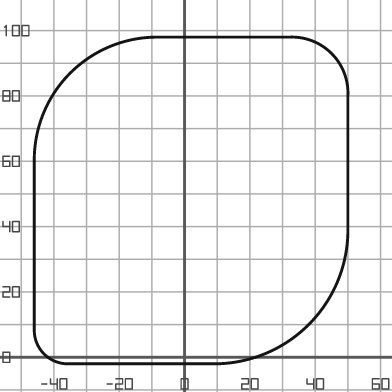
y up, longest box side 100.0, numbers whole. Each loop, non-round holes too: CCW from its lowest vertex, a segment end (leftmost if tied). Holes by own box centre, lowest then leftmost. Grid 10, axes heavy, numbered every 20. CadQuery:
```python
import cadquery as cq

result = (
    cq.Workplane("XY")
    .moveTo(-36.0, -2.0)
    .lineTo(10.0, -2.0)
    .threePointArc((38.0, 10.0), (50.0, 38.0))
    .lineTo(50.0, 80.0)
    .threePointArc((45.0, 93.0), (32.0, 98.0))
    .lineTo(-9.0, 98.0)
    .threePointArc((-35.0, 87.0), (-46.0, 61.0))
    .lineTo(-46.0, 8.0)
    .threePointArc((-43.0, 1.0), (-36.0, -2.0))
    .close()
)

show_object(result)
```